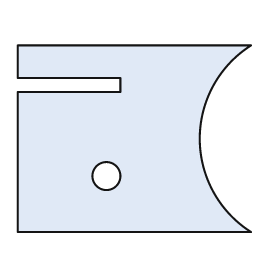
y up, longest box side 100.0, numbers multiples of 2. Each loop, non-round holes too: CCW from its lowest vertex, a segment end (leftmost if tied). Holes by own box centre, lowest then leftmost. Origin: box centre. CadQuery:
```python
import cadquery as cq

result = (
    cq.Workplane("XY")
    .moveTo(-50.0, -40.0)
    .lineTo(50.0, -40.0)
    .threePointArc((28.0, 0.0), (50.0, 40.0))
    .lineTo(-50.0, 40.0)
    .lineTo(-50.0, 26.0)
    .lineTo(-6.0, 26.0)
    .lineTo(-6.0, 20.0)
    .lineTo(-50.0, 20.0)
    .close()
    .moveTo(-12.0, -16.0)
    .circle(6.0)
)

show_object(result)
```